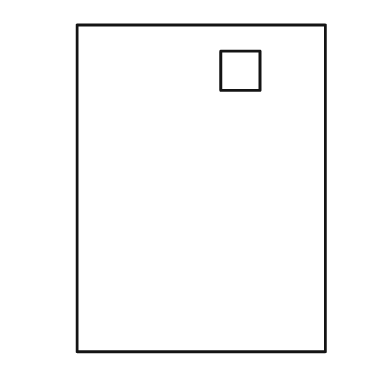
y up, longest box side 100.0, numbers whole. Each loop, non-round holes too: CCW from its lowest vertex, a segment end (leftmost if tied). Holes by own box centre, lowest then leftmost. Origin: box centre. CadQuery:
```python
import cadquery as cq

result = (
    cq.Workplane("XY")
    .moveTo(-38.0, -50.0)
    .lineTo(38.0, -50.0)
    .lineTo(38.0, 50.0)
    .lineTo(-38.0, 50.0)
    .close()
    .moveTo(6.0, 30.0)
    .lineTo(18.0, 30.0)
    .lineTo(18.0, 42.0)
    .lineTo(6.0, 42.0)
    .close()
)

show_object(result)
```